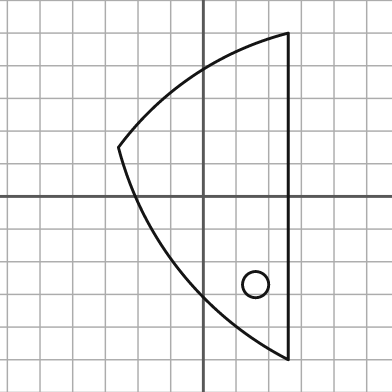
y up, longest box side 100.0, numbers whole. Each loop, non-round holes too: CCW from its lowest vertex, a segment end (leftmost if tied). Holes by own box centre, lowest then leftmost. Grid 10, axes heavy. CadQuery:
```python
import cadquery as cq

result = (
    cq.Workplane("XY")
    .moveTo(26.0, -50.0)
    .lineTo(26.0, 50.0)
    .threePointArc((-3.0, 37.0), (-26.0, 15.0))
    .threePointArc((-7.0, -23.0), (26.0, -50.0))
    .close()
    .moveTo(16.0, -27.0)
    .circle(4.0)
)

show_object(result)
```